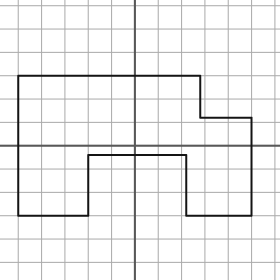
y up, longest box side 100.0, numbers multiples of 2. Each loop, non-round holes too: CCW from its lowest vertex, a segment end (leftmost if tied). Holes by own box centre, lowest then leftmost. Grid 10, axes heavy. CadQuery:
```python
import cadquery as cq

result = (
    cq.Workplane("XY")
    .moveTo(-50.0, -30.0)
    .lineTo(-20.0, -30.0)
    .lineTo(-20.0, -4.0)
    .lineTo(22.0, -4.0)
    .lineTo(22.0, -30.0)
    .lineTo(50.0, -30.0)
    .lineTo(50.0, 12.0)
    .lineTo(28.0, 12.0)
    .lineTo(28.0, 30.0)
    .lineTo(-50.0, 30.0)
    .close()
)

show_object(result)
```